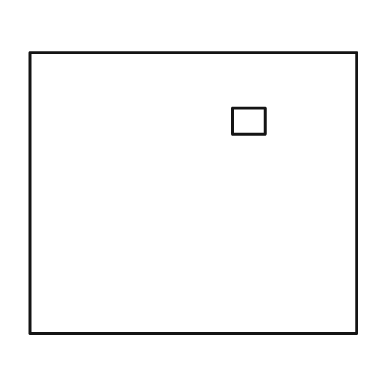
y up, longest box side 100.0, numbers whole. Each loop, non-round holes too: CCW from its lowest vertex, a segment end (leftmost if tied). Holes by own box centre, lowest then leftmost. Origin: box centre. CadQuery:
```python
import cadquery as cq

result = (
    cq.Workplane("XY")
    .moveTo(-50.0, -43.0)
    .lineTo(50.0, -43.0)
    .lineTo(50.0, 43.0)
    .lineTo(-50.0, 43.0)
    .close()
    .moveTo(12.0, 18.0)
    .lineTo(22.0, 18.0)
    .lineTo(22.0, 26.0)
    .lineTo(12.0, 26.0)
    .close()
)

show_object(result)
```